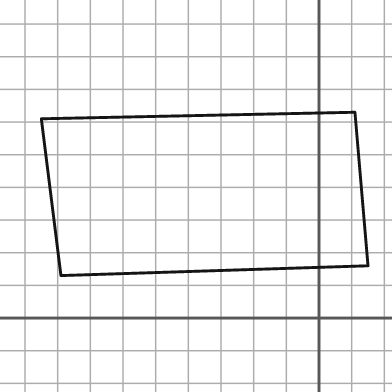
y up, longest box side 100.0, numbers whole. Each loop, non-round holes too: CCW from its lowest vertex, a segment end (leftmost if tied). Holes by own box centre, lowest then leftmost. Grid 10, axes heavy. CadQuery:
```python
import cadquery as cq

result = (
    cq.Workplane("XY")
    .moveTo(-79.0, 13.0)
    .lineTo(15.0, 16.0)
    .lineTo(11.0, 63.0)
    .lineTo(-85.0, 61.0)
    .close()
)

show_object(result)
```